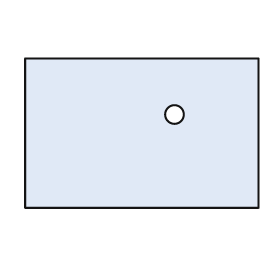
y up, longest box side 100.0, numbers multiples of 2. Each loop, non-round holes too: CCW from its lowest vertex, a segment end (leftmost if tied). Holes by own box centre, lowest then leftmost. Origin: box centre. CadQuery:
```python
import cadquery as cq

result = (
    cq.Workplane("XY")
    .moveTo(-50.0, -32.0)
    .lineTo(50.0, -32.0)
    .lineTo(50.0, 32.0)
    .lineTo(-50.0, 32.0)
    .close()
    .moveTo(14.0, 8.0)
    .circle(4.0)
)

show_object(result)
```